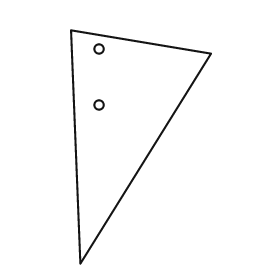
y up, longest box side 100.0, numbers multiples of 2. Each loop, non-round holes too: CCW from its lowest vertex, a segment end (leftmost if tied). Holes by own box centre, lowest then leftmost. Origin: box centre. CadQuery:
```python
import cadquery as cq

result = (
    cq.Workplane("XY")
    .moveTo(-26.0, -50.0)
    .lineTo(30.0, 40.0)
    .lineTo(-30.0, 50.0)
    .close()
    .moveTo(-18.0, 18.0)
    .circle(2.0)
    .moveTo(-18.0, 42.0)
    .circle(2.0)
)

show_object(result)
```